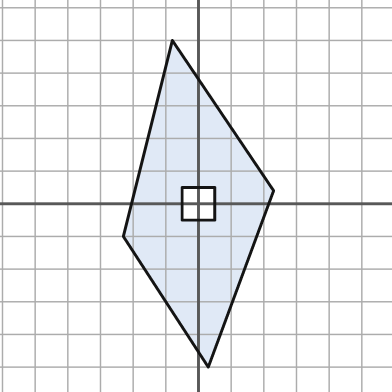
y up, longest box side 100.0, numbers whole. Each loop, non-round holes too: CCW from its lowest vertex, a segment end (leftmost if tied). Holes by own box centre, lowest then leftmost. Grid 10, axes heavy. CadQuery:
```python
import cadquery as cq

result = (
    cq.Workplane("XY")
    .moveTo(3.0, -50.0)
    .lineTo(23.0, 4.0)
    .lineTo(-8.0, 50.0)
    .lineTo(-23.0, -10.0)
    .close()
    .moveTo(-5.0, -5.0)
    .lineTo(5.0, -5.0)
    .lineTo(5.0, 5.0)
    .lineTo(-5.0, 5.0)
    .close()
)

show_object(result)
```